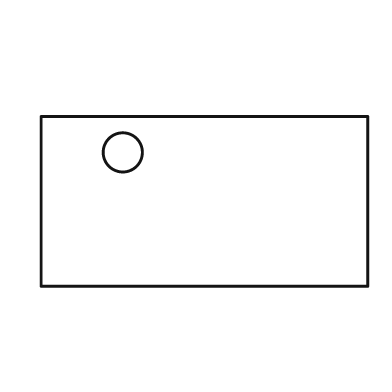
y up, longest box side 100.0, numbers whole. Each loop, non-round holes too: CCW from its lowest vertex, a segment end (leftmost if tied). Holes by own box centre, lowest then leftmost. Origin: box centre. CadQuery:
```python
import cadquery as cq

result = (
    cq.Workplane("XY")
    .moveTo(-50.0, -26.0)
    .lineTo(50.0, -26.0)
    .lineTo(50.0, 26.0)
    .lineTo(-50.0, 26.0)
    .close()
    .moveTo(-25.0, 15.0)
    .circle(6.0)
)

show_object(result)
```